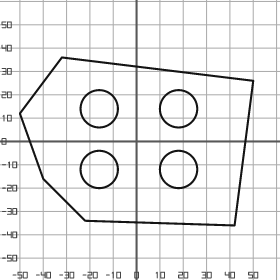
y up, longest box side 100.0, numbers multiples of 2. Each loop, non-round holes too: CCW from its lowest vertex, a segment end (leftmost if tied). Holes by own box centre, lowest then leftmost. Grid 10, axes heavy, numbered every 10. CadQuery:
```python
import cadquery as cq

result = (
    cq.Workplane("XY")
    .moveTo(42.0, -36.0)
    .lineTo(50.0, 26.0)
    .lineTo(-32.0, 36.0)
    .lineTo(-50.0, 12.0)
    .lineTo(-40.0, -16.0)
    .lineTo(-22.0, -34.0)
    .close()
    .moveTo(-16.0, -12.0)
    .circle(8.0)
    .moveTo(18.0, -12.0)
    .circle(8.0)
    .moveTo(-16.0, 14.0)
    .circle(8.0)
    .moveTo(18.0, 14.0)
    .circle(8.0)
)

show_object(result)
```